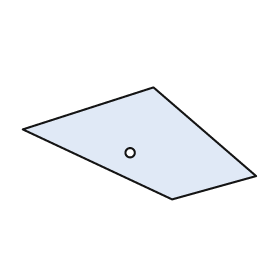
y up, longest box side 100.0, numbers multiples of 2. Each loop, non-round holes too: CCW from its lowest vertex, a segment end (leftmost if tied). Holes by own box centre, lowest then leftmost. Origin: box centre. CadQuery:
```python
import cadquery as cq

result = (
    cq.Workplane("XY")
    .moveTo(14.0, -24.0)
    .lineTo(50.0, -14.0)
    .lineTo(6.0, 24.0)
    .lineTo(-50.0, 6.0)
    .close()
    .moveTo(-4.0, -4.0)
    .circle(2.0)
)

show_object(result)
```